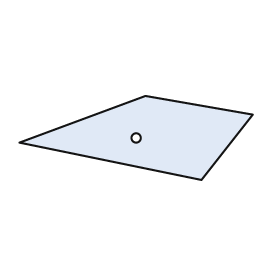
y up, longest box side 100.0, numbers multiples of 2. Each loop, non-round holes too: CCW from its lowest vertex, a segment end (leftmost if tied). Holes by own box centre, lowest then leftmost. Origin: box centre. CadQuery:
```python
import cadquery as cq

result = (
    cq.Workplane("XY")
    .moveTo(28.0, -18.0)
    .lineTo(50.0, 10.0)
    .lineTo(4.0, 18.0)
    .lineTo(-50.0, -2.0)
    .close()
    .moveTo(0.0, 0.0)
    .circle(2.0)
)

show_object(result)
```